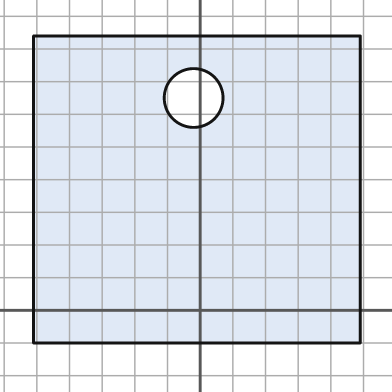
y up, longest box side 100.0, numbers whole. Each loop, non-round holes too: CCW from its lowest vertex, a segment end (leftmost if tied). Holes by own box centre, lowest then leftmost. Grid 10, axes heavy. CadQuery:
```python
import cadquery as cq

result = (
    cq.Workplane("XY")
    .moveTo(-51.0, -10.0)
    .lineTo(49.0, -10.0)
    .lineTo(49.0, 84.0)
    .lineTo(-51.0, 84.0)
    .close()
    .moveTo(-2.0, 65.0)
    .circle(9.0)
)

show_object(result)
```